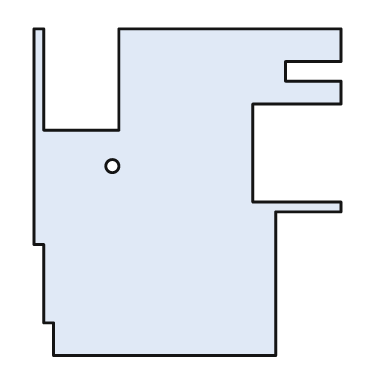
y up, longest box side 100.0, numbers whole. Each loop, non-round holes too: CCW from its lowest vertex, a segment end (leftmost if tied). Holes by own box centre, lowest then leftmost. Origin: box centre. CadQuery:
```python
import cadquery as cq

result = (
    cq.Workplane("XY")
    .moveTo(-41.0, -50.0)
    .lineTo(27.0, -50.0)
    .lineTo(27.0, -6.0)
    .lineTo(47.0, -6.0)
    .lineTo(47.0, -3.0)
    .lineTo(20.0, -3.0)
    .lineTo(20.0, 27.0)
    .lineTo(47.0, 27.0)
    .lineTo(47.0, 34.0)
    .lineTo(30.0, 34.0)
    .lineTo(30.0, 40.0)
    .lineTo(47.0, 40.0)
    .lineTo(47.0, 50.0)
    .lineTo(-21.0, 50.0)
    .lineTo(-21.0, 19.0)
    .lineTo(-44.0, 19.0)
    .lineTo(-44.0, 50.0)
    .lineTo(-47.0, 50.0)
    .lineTo(-47.0, -16.0)
    .lineTo(-44.0, -16.0)
    .lineTo(-44.0, -40.0)
    .lineTo(-41.0, -40.0)
    .close()
    .moveTo(-23.0, 8.0)
    .circle(2.0)
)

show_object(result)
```